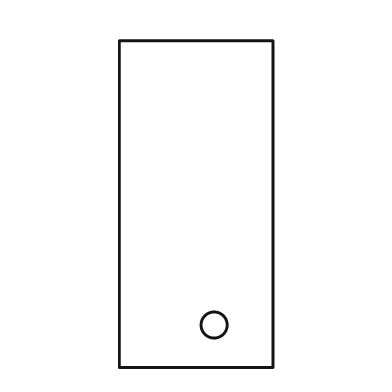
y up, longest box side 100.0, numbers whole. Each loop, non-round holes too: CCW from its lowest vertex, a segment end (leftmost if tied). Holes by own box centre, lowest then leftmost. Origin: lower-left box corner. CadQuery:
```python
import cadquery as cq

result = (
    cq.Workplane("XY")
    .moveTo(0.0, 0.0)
    .lineTo(47.0, 0.0)
    .lineTo(47.0, 100.0)
    .lineTo(0.0, 100.0)
    .close()
    .moveTo(29.0, 13.0)
    .circle(4.0)
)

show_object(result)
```